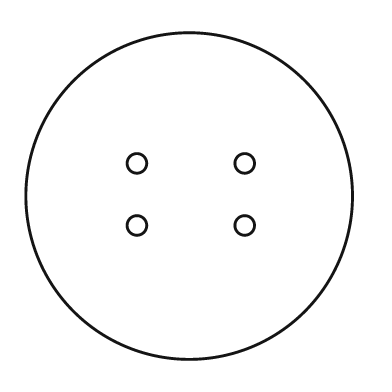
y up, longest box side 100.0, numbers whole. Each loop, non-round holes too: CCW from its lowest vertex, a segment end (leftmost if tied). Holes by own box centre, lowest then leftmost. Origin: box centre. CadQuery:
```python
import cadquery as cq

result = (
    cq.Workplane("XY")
    .moveTo(0.0, 0.0)
    .circle(50.0)
    .moveTo(-16.0, -9.0)
    .circle(3.0)
    .moveTo(17.0, -9.0)
    .circle(3.0)
    .moveTo(-16.0, 10.0)
    .circle(3.0)
    .moveTo(17.0, 10.0)
    .circle(3.0)
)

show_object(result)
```